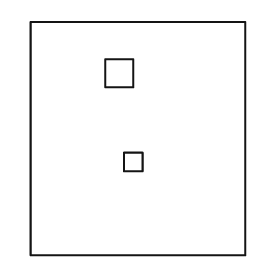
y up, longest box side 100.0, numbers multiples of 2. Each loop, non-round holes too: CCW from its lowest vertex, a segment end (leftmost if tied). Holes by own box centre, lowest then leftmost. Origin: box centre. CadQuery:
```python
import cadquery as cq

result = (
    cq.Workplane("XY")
    .moveTo(-46.0, -50.0)
    .lineTo(46.0, -50.0)
    .lineTo(46.0, 50.0)
    .lineTo(-46.0, 50.0)
    .close()
    .moveTo(-6.0, -14.0)
    .lineTo(2.0, -14.0)
    .lineTo(2.0, -6.0)
    .lineTo(-6.0, -6.0)
    .close()
    .moveTo(-14.0, 22.0)
    .lineTo(-2.0, 22.0)
    .lineTo(-2.0, 34.0)
    .lineTo(-14.0, 34.0)
    .close()
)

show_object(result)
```